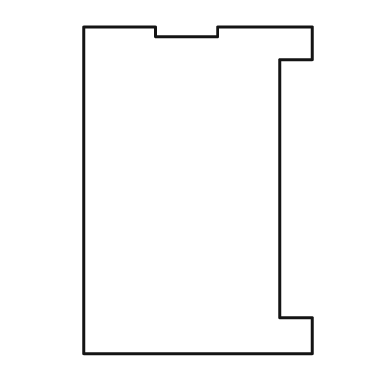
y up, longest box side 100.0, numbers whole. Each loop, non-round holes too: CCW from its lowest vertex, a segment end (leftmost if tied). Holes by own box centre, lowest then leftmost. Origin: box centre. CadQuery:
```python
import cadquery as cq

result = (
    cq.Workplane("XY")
    .moveTo(-35.0, -50.0)
    .lineTo(35.0, -50.0)
    .lineTo(35.0, -39.0)
    .lineTo(25.0, -39.0)
    .lineTo(25.0, 40.0)
    .lineTo(35.0, 40.0)
    .lineTo(35.0, 50.0)
    .lineTo(6.0, 50.0)
    .lineTo(6.0, 47.0)
    .lineTo(-13.0, 47.0)
    .lineTo(-13.0, 50.0)
    .lineTo(-35.0, 50.0)
    .close()
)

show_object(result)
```